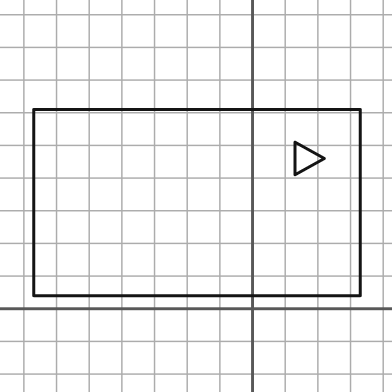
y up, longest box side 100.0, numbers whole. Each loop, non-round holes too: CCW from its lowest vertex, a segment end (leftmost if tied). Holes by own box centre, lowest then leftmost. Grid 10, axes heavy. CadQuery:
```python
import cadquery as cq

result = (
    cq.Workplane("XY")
    .moveTo(-67.0, 4.0)
    .lineTo(33.0, 4.0)
    .lineTo(33.0, 61.0)
    .lineTo(-67.0, 61.0)
    .close()
    .moveTo(13.0, 41.0)
    .lineTo(22.0, 46.0)
    .lineTo(13.0, 51.0)
    .close()
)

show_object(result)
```